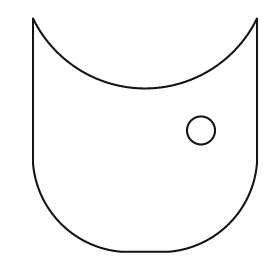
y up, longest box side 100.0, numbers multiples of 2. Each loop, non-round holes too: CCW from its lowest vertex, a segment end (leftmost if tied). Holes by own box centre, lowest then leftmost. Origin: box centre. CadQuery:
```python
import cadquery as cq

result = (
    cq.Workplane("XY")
    .moveTo(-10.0, -50.0)
    .lineTo(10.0, -50.0)
    .threePointArc((36.0, -38.0), (48.0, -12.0))
    .lineTo(48.0, 50.0)
    .threePointArc((0.0, 20.0), (-48.0, 50.0))
    .lineTo(-48.0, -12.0)
    .threePointArc((-36.0, -38.0), (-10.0, -50.0))
    .close()
    .moveTo(24.0, 2.0)
    .circle(6.0)
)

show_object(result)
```